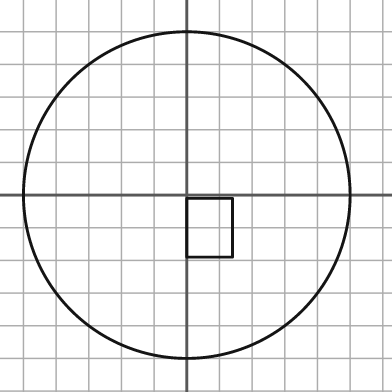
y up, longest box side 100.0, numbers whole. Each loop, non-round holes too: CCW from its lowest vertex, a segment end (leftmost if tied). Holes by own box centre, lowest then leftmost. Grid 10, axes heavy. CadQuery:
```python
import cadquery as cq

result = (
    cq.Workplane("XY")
    .moveTo(0.0, 0.0)
    .circle(50.0)
    .moveTo(0.0, -19.0)
    .lineTo(14.0, -19.0)
    .lineTo(14.0, -1.0)
    .lineTo(0.0, -1.0)
    .close()
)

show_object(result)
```